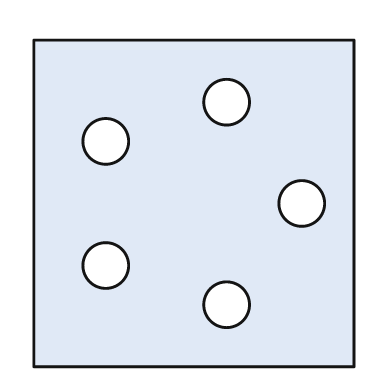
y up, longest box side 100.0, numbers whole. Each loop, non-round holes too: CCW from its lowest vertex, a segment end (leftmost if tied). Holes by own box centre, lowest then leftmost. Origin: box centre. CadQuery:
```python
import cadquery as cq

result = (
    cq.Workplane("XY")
    .moveTo(-49.0, -50.0)
    .lineTo(49.0, -50.0)
    .lineTo(49.0, 50.0)
    .lineTo(-49.0, 50.0)
    .close()
    .moveTo(10.0, -31.0)
    .circle(7.0)
    .moveTo(-27.0, -19.0)
    .circle(7.0)
    .moveTo(33.0, 0.0)
    .circle(7.0)
    .moveTo(-27.0, 19.0)
    .circle(7.0)
    .moveTo(10.0, 31.0)
    .circle(7.0)
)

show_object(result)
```